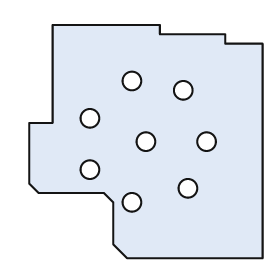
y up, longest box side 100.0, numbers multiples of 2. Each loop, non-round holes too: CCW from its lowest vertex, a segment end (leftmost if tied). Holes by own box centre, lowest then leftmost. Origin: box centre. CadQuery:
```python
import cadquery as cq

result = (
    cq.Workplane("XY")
    .moveTo(-8.0, -50.0)
    .lineTo(50.0, -50.0)
    .lineTo(50.0, 42.0)
    .lineTo(34.0, 42.0)
    .lineTo(34.0, 46.0)
    .lineTo(6.0, 46.0)
    .lineTo(6.0, 50.0)
    .lineTo(-40.0, 50.0)
    .lineTo(-40.0, 8.0)
    .lineTo(-50.0, 8.0)
    .lineTo(-50.0, -18.0)
    .lineTo(-46.0, -22.0)
    .lineTo(-18.0, -22.0)
    .lineTo(-14.0, -26.0)
    .lineTo(-14.0, -44.0)
    .close()
    .moveTo(-6.0, -26.0)
    .circle(4.0)
    .moveTo(18.0, -20.0)
    .circle(4.0)
    .moveTo(-24.0, -12.0)
    .circle(4.0)
    .moveTo(0.0, 0.0)
    .circle(4.0)
    .moveTo(26.0, 0.0)
    .circle(4.0)
    .moveTo(-24.0, 10.0)
    .circle(4.0)
    .moveTo(16.0, 22.0)
    .circle(4.0)
    .moveTo(-6.0, 26.0)
    .circle(4.0)
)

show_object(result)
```